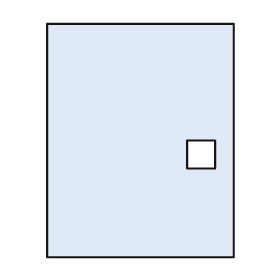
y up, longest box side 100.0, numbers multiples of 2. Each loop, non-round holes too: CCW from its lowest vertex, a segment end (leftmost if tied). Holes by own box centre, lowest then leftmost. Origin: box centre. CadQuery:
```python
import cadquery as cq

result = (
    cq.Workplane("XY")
    .moveTo(-40.0, -50.0)
    .lineTo(40.0, -50.0)
    .lineTo(40.0, 50.0)
    .lineTo(-40.0, 50.0)
    .close()
    .moveTo(20.0, -12.0)
    .lineTo(32.0, -12.0)
    .lineTo(32.0, 0.0)
    .lineTo(20.0, 0.0)
    .close()
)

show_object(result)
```